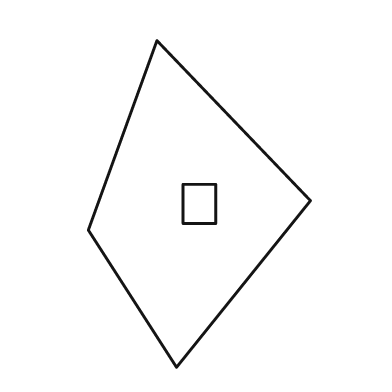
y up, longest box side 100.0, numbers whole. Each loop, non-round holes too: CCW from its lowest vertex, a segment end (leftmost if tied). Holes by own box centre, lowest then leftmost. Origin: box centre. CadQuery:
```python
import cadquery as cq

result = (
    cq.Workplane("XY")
    .moveTo(-7.0, -50.0)
    .lineTo(34.0, 1.0)
    .lineTo(-13.0, 50.0)
    .lineTo(-34.0, -8.0)
    .close()
    .moveTo(-5.0, -6.0)
    .lineTo(5.0, -6.0)
    .lineTo(5.0, 6.0)
    .lineTo(-5.0, 6.0)
    .close()
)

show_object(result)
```